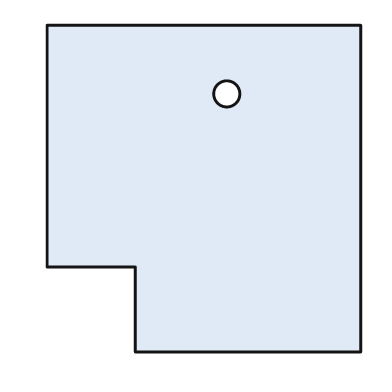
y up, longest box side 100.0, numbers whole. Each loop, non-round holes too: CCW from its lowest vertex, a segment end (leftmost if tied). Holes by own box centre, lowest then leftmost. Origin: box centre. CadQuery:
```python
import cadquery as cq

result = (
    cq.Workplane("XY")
    .moveTo(-21.0, -50.0)
    .lineTo(48.0, -50.0)
    .lineTo(48.0, 50.0)
    .lineTo(-48.0, 50.0)
    .lineTo(-48.0, -24.0)
    .lineTo(-21.0, -24.0)
    .close()
    .moveTo(7.0, 29.0)
    .circle(4.0)
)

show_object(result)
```